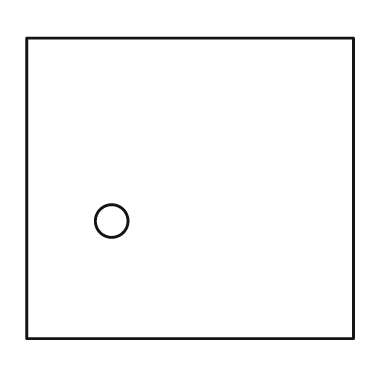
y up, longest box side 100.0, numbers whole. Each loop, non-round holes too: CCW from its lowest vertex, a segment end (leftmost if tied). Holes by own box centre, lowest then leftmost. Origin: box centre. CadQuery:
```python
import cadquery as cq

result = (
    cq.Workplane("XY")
    .moveTo(-50.0, -46.0)
    .lineTo(50.0, -46.0)
    .lineTo(50.0, 46.0)
    .lineTo(-50.0, 46.0)
    .close()
    .moveTo(-24.0, -10.0)
    .circle(5.0)
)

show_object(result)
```